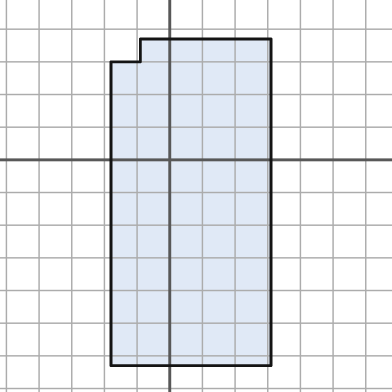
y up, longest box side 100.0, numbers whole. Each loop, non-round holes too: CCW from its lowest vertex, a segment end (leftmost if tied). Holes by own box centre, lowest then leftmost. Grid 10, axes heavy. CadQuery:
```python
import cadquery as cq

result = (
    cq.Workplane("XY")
    .moveTo(-18.0, -63.0)
    .lineTo(31.0, -63.0)
    .lineTo(31.0, 37.0)
    .lineTo(-9.0, 37.0)
    .lineTo(-9.0, 30.0)
    .lineTo(-18.0, 30.0)
    .close()
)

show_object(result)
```